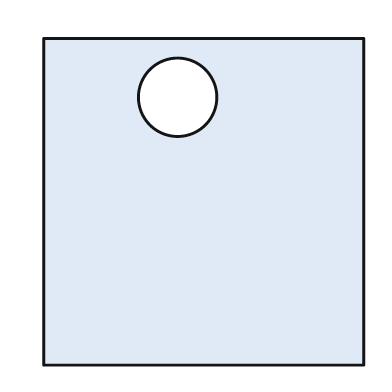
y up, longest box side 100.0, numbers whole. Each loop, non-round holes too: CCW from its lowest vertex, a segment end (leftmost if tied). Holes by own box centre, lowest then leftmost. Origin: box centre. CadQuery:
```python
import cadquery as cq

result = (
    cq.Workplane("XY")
    .moveTo(-49.0, -50.0)
    .lineTo(49.0, -50.0)
    .lineTo(49.0, 50.0)
    .lineTo(-49.0, 50.0)
    .close()
    .moveTo(-8.0, 32.0)
    .circle(12.0)
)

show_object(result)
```